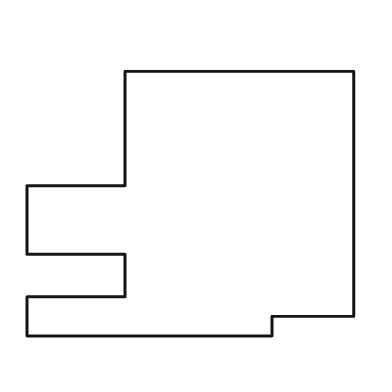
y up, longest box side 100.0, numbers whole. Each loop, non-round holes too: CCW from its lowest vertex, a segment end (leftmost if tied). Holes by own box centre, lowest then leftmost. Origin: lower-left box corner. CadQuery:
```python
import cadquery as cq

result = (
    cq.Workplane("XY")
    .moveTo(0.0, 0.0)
    .lineTo(75.0, 0.0)
    .lineTo(75.0, 6.0)
    .lineTo(100.0, 6.0)
    .lineTo(100.0, 81.0)
    .lineTo(30.0, 81.0)
    .lineTo(30.0, 46.0)
    .lineTo(0.0, 46.0)
    .lineTo(0.0, 25.0)
    .lineTo(30.0, 25.0)
    .lineTo(30.0, 12.0)
    .lineTo(0.0, 12.0)
    .close()
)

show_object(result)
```